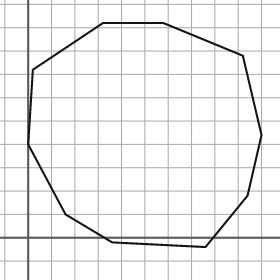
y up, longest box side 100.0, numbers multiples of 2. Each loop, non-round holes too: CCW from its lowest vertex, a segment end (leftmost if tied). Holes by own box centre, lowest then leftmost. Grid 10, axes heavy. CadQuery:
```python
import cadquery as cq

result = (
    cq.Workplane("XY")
    .moveTo(76.0, -4.0)
    .lineTo(94.0, 18.0)
    .lineTo(100.0, 44.0)
    .lineTo(92.0, 78.0)
    .lineTo(58.0, 92.0)
    .lineTo(32.0, 92.0)
    .lineTo(2.0, 72.0)
    .lineTo(0.0, 40.0)
    .lineTo(16.0, 10.0)
    .lineTo(36.0, -2.0)
    .close()
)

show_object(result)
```